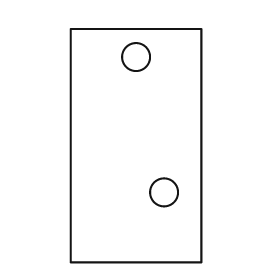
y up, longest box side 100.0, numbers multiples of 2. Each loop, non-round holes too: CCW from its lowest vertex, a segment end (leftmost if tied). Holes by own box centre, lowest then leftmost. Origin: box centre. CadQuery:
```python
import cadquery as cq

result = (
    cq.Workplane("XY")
    .moveTo(-28.0, -50.0)
    .lineTo(28.0, -50.0)
    .lineTo(28.0, 50.0)
    .lineTo(-28.0, 50.0)
    .close()
    .moveTo(12.0, -20.0)
    .circle(6.0)
    .moveTo(0.0, 38.0)
    .circle(6.0)
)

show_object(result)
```